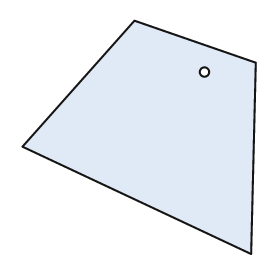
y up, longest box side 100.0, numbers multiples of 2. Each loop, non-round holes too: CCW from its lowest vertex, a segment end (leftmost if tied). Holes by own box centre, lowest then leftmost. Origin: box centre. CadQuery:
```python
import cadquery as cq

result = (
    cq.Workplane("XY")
    .moveTo(48.0, -50.0)
    .lineTo(50.0, 32.0)
    .lineTo(-2.0, 50.0)
    .lineTo(-50.0, -4.0)
    .close()
    .moveTo(28.0, 28.0)
    .circle(2.0)
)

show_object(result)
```